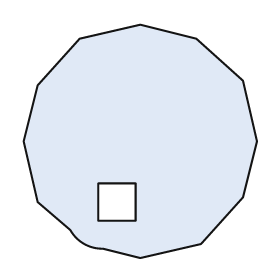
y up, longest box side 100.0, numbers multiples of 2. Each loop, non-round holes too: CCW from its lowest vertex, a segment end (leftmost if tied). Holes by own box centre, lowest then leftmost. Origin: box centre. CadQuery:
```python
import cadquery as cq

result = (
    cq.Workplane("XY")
    .moveTo(0.0, -50.0)
    .lineTo(26.0, -44.0)
    .lineTo(44.0, -24.0)
    .lineTo(50.0, 0.0)
    .lineTo(44.0, 26.0)
    .lineTo(24.0, 44.0)
    .lineTo(0.0, 50.0)
    .lineTo(-26.0, 44.0)
    .lineTo(-44.0, 24.0)
    .lineTo(-50.0, 0.0)
    .lineTo(-44.0, -26.0)
    .lineTo(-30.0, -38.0)
    .threePointArc((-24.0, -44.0), (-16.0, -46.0))
    .close()
    .moveTo(-18.0, -34.0)
    .lineTo(-2.0, -34.0)
    .lineTo(-2.0, -18.0)
    .lineTo(-18.0, -18.0)
    .close()
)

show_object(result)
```